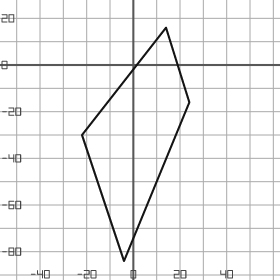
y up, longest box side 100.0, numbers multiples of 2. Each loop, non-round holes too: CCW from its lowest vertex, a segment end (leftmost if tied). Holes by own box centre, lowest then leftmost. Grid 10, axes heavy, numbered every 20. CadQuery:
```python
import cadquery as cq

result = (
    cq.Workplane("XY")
    .moveTo(-4.0, -84.0)
    .lineTo(24.0, -16.0)
    .lineTo(14.0, 16.0)
    .lineTo(-22.0, -30.0)
    .close()
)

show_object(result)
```